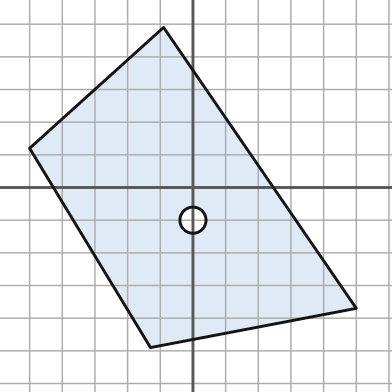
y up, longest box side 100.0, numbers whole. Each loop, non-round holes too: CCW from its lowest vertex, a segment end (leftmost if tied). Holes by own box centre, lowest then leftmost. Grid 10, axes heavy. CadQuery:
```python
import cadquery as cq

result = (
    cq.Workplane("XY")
    .moveTo(-13.0, -49.0)
    .lineTo(50.0, -37.0)
    .lineTo(-9.0, 49.0)
    .lineTo(-50.0, 12.0)
    .close()
    .moveTo(0.0, -10.0)
    .circle(4.0)
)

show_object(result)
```